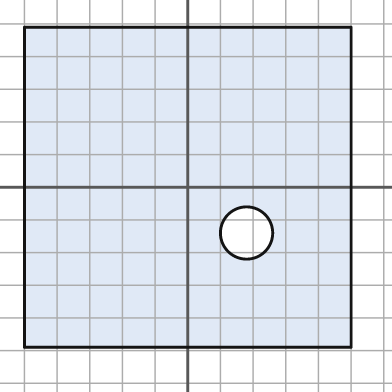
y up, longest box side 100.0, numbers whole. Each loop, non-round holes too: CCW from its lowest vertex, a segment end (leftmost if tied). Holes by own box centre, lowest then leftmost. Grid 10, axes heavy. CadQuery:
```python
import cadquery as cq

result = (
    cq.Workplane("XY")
    .moveTo(-50.0, -49.0)
    .lineTo(50.0, -49.0)
    .lineTo(50.0, 49.0)
    .lineTo(-50.0, 49.0)
    .close()
    .moveTo(18.0, -14.0)
    .circle(8.0)
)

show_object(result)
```